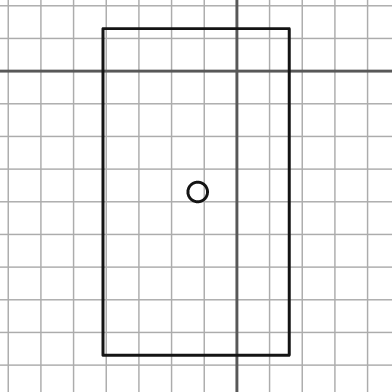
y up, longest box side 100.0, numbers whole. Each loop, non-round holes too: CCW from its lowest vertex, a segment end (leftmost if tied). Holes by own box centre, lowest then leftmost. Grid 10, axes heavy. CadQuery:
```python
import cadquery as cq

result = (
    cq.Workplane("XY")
    .moveTo(-41.0, -87.0)
    .lineTo(16.0, -87.0)
    .lineTo(16.0, 13.0)
    .lineTo(-41.0, 13.0)
    .close()
    .moveTo(-12.0, -37.0)
    .circle(3.0)
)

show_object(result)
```